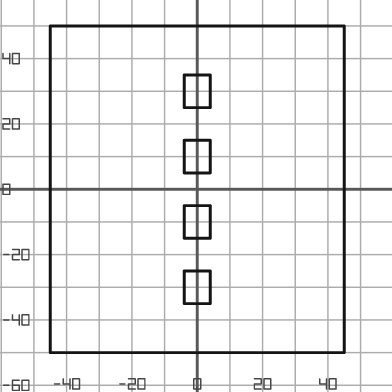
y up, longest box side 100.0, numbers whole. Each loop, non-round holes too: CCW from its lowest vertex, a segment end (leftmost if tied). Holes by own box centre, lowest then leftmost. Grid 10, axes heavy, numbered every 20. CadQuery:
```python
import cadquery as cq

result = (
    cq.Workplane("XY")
    .moveTo(-45.0, -50.0)
    .lineTo(45.0, -50.0)
    .lineTo(45.0, 50.0)
    .lineTo(-45.0, 50.0)
    .close()
    .moveTo(-4.0, -35.0)
    .lineTo(4.0, -35.0)
    .lineTo(4.0, -25.0)
    .lineTo(-4.0, -25.0)
    .close()
    .moveTo(-4.0, -15.0)
    .lineTo(4.0, -15.0)
    .lineTo(4.0, -5.0)
    .lineTo(-4.0, -5.0)
    .close()
    .moveTo(-4.0, 5.0)
    .lineTo(4.0, 5.0)
    .lineTo(4.0, 15.0)
    .lineTo(-4.0, 15.0)
    .close()
    .moveTo(-4.0, 25.0)
    .lineTo(4.0, 25.0)
    .lineTo(4.0, 35.0)
    .lineTo(-4.0, 35.0)
    .close()
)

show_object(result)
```